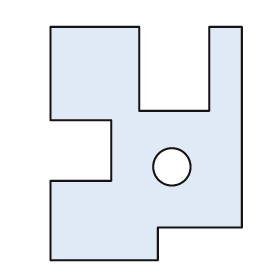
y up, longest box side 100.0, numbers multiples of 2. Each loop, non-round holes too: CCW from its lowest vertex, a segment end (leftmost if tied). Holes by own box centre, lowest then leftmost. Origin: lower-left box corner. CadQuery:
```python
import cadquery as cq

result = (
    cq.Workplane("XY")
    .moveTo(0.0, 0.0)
    .lineTo(46.0, 0.0)
    .lineTo(46.0, 14.0)
    .lineTo(82.0, 14.0)
    .lineTo(82.0, 100.0)
    .lineTo(68.0, 100.0)
    .lineTo(68.0, 64.0)
    .lineTo(38.0, 64.0)
    .lineTo(38.0, 100.0)
    .lineTo(0.0, 100.0)
    .lineTo(0.0, 60.0)
    .lineTo(26.0, 60.0)
    .lineTo(26.0, 34.0)
    .lineTo(0.0, 34.0)
    .close()
    .moveTo(52.0, 40.0)
    .circle(8.0)
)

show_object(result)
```